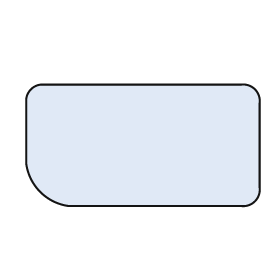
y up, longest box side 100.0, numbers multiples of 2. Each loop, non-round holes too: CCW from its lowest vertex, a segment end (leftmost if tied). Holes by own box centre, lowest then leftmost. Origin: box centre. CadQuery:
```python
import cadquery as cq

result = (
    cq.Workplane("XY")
    .moveTo(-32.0, -26.0)
    .lineTo(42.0, -26.0)
    .threePointArc((48.0, -24.0), (50.0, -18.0))
    .lineTo(50.0, 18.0)
    .threePointArc((48.0, 24.0), (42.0, 26.0))
    .lineTo(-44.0, 26.0)
    .threePointArc((-48.0, 24.0), (-50.0, 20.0))
    .lineTo(-50.0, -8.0)
    .threePointArc((-44.0, -20.0), (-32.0, -26.0))
    .close()
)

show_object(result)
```